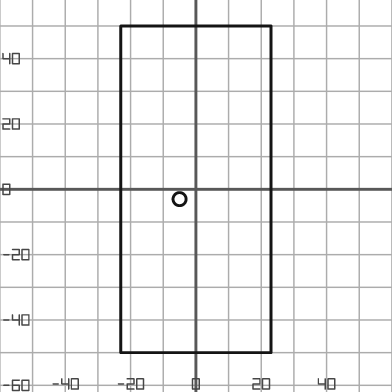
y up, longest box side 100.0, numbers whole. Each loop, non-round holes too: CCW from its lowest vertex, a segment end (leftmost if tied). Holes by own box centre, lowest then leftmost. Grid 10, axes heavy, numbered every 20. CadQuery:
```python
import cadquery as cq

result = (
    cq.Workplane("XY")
    .moveTo(-23.0, -50.0)
    .lineTo(23.0, -50.0)
    .lineTo(23.0, 50.0)
    .lineTo(-23.0, 50.0)
    .close()
    .moveTo(-5.0, -3.0)
    .circle(2.0)
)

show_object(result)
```